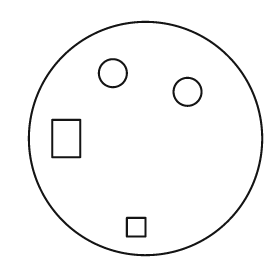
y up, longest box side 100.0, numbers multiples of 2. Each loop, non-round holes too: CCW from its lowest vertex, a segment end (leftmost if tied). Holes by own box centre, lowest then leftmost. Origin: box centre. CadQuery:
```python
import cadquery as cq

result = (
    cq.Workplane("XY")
    .moveTo(0.0, 0.0)
    .circle(50.0)
    .moveTo(-8.0, -42.0)
    .lineTo(0.0, -42.0)
    .lineTo(0.0, -34.0)
    .lineTo(-8.0, -34.0)
    .close()
    .moveTo(-40.0, -8.0)
    .lineTo(-28.0, -8.0)
    .lineTo(-28.0, 8.0)
    .lineTo(-40.0, 8.0)
    .close()
    .moveTo(18.0, 20.0)
    .circle(6.0)
    .moveTo(-14.0, 28.0)
    .circle(6.0)
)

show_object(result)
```